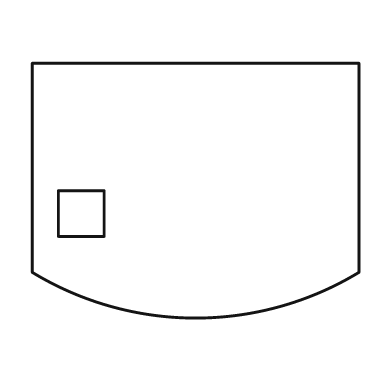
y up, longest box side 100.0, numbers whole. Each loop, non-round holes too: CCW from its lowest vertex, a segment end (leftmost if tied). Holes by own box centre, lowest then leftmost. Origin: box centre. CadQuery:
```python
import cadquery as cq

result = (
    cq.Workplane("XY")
    .moveTo(-50.0, -25.0)
    .threePointArc((0.0, -39.0), (50.0, -25.0))
    .lineTo(50.0, 39.0)
    .lineTo(-50.0, 39.0)
    .close()
    .moveTo(-42.0, -14.0)
    .lineTo(-28.0, -14.0)
    .lineTo(-28.0, 0.0)
    .lineTo(-42.0, 0.0)
    .close()
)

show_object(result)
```